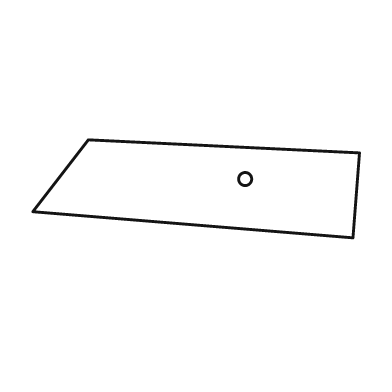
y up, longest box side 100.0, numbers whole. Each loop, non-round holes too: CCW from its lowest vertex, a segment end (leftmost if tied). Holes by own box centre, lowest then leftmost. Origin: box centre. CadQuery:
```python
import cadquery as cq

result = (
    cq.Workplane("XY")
    .moveTo(48.0, -15.0)
    .lineTo(50.0, 11.0)
    .lineTo(-33.0, 15.0)
    .lineTo(-50.0, -7.0)
    .close()
    .moveTo(15.0, 3.0)
    .circle(2.0)
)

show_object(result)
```